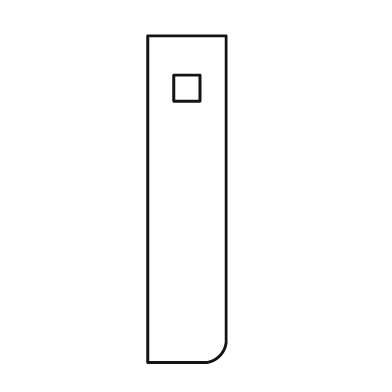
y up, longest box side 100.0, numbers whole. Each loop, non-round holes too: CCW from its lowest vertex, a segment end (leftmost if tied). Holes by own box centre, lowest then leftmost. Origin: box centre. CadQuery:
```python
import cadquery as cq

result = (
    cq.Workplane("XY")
    .moveTo(-12.0, -50.0)
    .lineTo(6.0, -50.0)
    .threePointArc((10.0, -48.0), (12.0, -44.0))
    .lineTo(12.0, 50.0)
    .lineTo(-12.0, 50.0)
    .close()
    .moveTo(-4.0, 30.0)
    .lineTo(4.0, 30.0)
    .lineTo(4.0, 38.0)
    .lineTo(-4.0, 38.0)
    .close()
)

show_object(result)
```